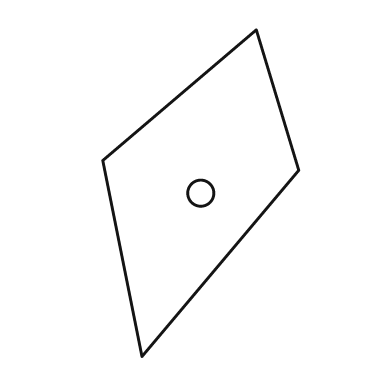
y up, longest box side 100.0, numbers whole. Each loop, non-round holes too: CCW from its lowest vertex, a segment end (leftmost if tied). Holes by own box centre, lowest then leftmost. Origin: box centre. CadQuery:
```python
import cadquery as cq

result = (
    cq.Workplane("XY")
    .moveTo(-18.0, -50.0)
    .lineTo(30.0, 7.0)
    .lineTo(17.0, 50.0)
    .lineTo(-30.0, 10.0)
    .close()
    .moveTo(0.0, 0.0)
    .circle(4.0)
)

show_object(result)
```